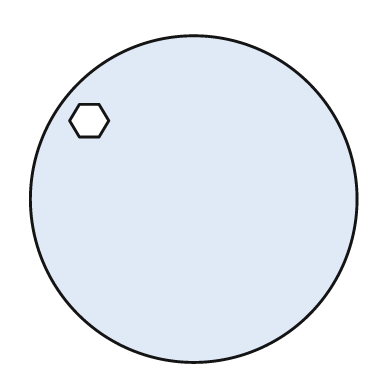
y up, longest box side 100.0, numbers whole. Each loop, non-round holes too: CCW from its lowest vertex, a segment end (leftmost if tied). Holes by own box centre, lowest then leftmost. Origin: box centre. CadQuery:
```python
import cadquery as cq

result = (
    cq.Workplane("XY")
    .moveTo(0.0, 0.0)
    .circle(50.0)
    .moveTo(-35.0, 19.0)
    .lineTo(-29.0, 19.0)
    .lineTo(-26.0, 24.0)
    .lineTo(-29.0, 29.0)
    .lineTo(-35.0, 29.0)
    .lineTo(-38.0, 24.0)
    .close()
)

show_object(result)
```